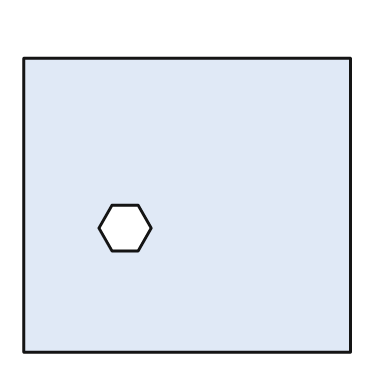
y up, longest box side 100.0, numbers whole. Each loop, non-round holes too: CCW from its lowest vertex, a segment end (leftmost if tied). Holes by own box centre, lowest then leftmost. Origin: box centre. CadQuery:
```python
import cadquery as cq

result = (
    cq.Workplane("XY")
    .moveTo(-50.0, -45.0)
    .lineTo(50.0, -45.0)
    .lineTo(50.0, 45.0)
    .lineTo(-50.0, 45.0)
    .close()
    .moveTo(-23.0, -14.0)
    .lineTo(-15.0, -14.0)
    .lineTo(-11.0, -7.0)
    .lineTo(-15.0, 0.0)
    .lineTo(-23.0, 0.0)
    .lineTo(-27.0, -7.0)
    .close()
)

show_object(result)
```